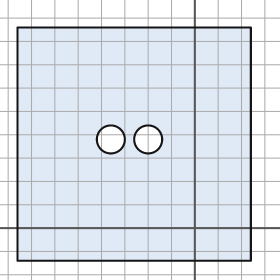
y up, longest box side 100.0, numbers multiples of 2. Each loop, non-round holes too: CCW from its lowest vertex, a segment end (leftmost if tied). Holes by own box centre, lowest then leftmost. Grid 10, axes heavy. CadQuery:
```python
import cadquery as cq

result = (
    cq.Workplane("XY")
    .moveTo(-76.0, -14.0)
    .lineTo(24.0, -14.0)
    .lineTo(24.0, 86.0)
    .lineTo(-76.0, 86.0)
    .close()
    .moveTo(-36.0, 38.0)
    .circle(6.0)
    .moveTo(-20.0, 38.0)
    .circle(6.0)
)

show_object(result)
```